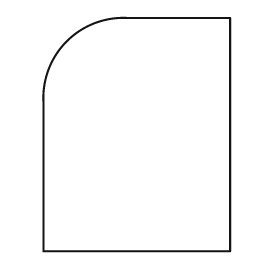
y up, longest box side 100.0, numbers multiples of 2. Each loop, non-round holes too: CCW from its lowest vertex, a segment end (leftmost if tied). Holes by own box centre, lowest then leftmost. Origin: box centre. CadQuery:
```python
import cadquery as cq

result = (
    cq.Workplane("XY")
    .moveTo(-40.0, -50.0)
    .lineTo(40.0, -50.0)
    .lineTo(40.0, 50.0)
    .lineTo(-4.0, 50.0)
    .threePointArc((-30.0, 40.0), (-40.0, 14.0))
    .close()
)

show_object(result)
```